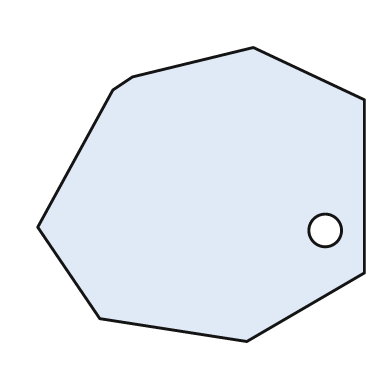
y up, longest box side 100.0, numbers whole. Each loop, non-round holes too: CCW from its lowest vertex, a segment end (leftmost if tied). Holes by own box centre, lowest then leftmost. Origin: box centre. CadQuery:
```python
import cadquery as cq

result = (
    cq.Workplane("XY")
    .moveTo(14.0, -45.0)
    .lineTo(50.0, -24.0)
    .lineTo(50.0, 29.0)
    .lineTo(16.0, 45.0)
    .lineTo(-21.0, 36.0)
    .lineTo(-27.0, 32.0)
    .lineTo(-50.0, -10.0)
    .lineTo(-31.0, -38.0)
    .close()
    .moveTo(38.0, -11.0)
    .circle(5.0)
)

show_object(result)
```